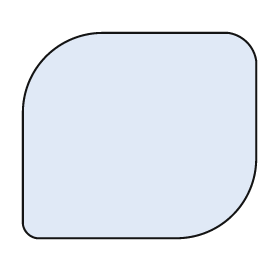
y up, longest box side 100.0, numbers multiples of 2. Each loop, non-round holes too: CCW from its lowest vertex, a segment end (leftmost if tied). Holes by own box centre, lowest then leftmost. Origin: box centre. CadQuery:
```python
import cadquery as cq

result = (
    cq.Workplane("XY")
    .moveTo(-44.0, -44.0)
    .lineTo(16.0, -44.0)
    .threePointArc((40.0, -34.0), (50.0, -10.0))
    .lineTo(50.0, 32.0)
    .threePointArc((46.0, 40.0), (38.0, 44.0))
    .lineTo(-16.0, 44.0)
    .threePointArc((-40.0, 34.0), (-50.0, 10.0))
    .lineTo(-50.0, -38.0)
    .threePointArc((-48.0, -42.0), (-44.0, -44.0))
    .close()
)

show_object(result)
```